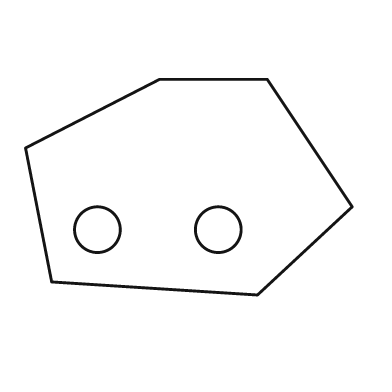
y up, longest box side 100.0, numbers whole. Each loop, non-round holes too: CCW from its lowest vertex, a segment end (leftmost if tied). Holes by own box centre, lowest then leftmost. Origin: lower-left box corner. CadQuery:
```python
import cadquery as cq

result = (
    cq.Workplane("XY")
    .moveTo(71.0, 0.0)
    .lineTo(100.0, 27.0)
    .lineTo(74.0, 66.0)
    .lineTo(41.0, 66.0)
    .lineTo(0.0, 45.0)
    .lineTo(8.0, 4.0)
    .close()
    .moveTo(22.0, 20.0)
    .circle(7.0)
    .moveTo(59.0, 20.0)
    .circle(7.0)
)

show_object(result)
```